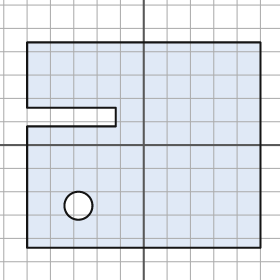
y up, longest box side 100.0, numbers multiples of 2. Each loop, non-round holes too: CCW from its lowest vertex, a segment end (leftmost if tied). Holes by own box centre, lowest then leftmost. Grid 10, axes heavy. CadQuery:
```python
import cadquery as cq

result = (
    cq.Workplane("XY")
    .moveTo(-50.0, -44.0)
    .lineTo(50.0, -44.0)
    .lineTo(50.0, 44.0)
    .lineTo(-50.0, 44.0)
    .lineTo(-50.0, 16.0)
    .lineTo(-12.0, 16.0)
    .lineTo(-12.0, 8.0)
    .lineTo(-50.0, 8.0)
    .close()
    .moveTo(-28.0, -26.0)
    .circle(6.0)
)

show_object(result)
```